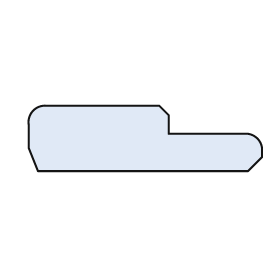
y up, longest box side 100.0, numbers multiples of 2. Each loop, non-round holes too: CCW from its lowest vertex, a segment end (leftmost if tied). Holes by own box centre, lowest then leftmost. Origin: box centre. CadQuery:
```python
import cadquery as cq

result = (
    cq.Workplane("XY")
    .moveTo(-46.0, -14.0)
    .lineTo(44.0, -14.0)
    .lineTo(50.0, -8.0)
    .lineTo(50.0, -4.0)
    .threePointArc((48.0, 0.0), (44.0, 2.0))
    .lineTo(10.0, 2.0)
    .lineTo(10.0, 10.0)
    .lineTo(6.0, 14.0)
    .lineTo(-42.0, 14.0)
    .threePointArc((-48.0, 12.0), (-50.0, 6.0))
    .lineTo(-50.0, -4.0)
    .close()
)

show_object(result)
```